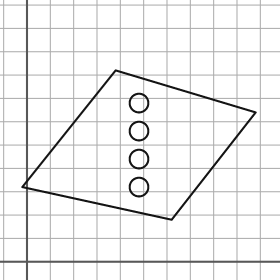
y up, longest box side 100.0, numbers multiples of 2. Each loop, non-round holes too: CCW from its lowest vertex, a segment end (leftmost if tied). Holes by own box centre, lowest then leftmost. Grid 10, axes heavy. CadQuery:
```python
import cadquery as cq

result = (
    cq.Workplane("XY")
    .moveTo(62.0, 18.0)
    .lineTo(98.0, 64.0)
    .lineTo(38.0, 82.0)
    .lineTo(-2.0, 32.0)
    .close()
    .moveTo(48.0, 32.0)
    .circle(4.0)
    .moveTo(48.0, 44.0)
    .circle(4.0)
    .moveTo(48.0, 56.0)
    .circle(4.0)
    .moveTo(48.0, 68.0)
    .circle(4.0)
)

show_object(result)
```